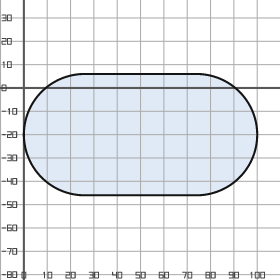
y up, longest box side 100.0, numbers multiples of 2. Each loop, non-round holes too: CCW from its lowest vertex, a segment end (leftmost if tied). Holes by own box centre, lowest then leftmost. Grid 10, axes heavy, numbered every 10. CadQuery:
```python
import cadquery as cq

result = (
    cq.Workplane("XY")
    .moveTo(26.0, -46.0)
    .lineTo(74.0, -46.0)
    .threePointArc((100.0, -20.0), (74.0, 6.0))
    .lineTo(26.0, 6.0)
    .threePointArc((0.0, -20.0), (26.0, -46.0))
    .close()
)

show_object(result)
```